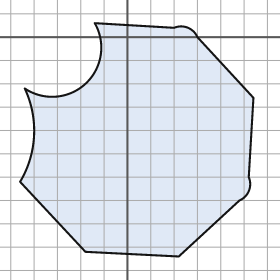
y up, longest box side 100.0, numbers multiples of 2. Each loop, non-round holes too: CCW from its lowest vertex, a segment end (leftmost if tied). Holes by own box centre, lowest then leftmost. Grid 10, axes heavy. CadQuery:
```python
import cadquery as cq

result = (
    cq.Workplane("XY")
    .moveTo(22.0, -94.0)
    .lineTo(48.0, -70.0)
    .threePointArc((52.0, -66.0), (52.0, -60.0))
    .lineTo(54.0, -26.0)
    .lineTo(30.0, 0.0)
    .threePointArc((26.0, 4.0), (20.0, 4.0))
    .lineTo(-14.0, 6.0)
    .threePointArc((-18.0, -20.0), (-44.0, -22.0))
    .threePointArc((-40.0, -42.0), (-46.0, -62.0))
    .lineTo(-18.0, -92.0)
    .close()
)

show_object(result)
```